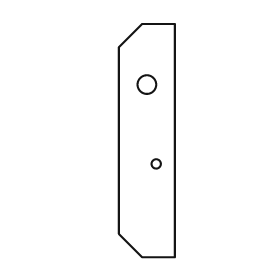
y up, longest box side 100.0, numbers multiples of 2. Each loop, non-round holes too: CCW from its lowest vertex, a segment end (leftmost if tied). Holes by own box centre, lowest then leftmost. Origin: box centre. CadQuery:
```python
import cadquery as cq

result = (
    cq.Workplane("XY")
    .moveTo(-2.0, -50.0)
    .lineTo(12.0, -50.0)
    .lineTo(12.0, 50.0)
    .lineTo(-2.0, 50.0)
    .lineTo(-12.0, 40.0)
    .lineTo(-12.0, -40.0)
    .close()
    .moveTo(4.0, -10.0)
    .circle(2.0)
    .moveTo(0.0, 24.0)
    .circle(4.0)
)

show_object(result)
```